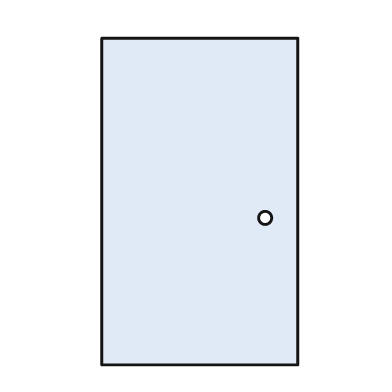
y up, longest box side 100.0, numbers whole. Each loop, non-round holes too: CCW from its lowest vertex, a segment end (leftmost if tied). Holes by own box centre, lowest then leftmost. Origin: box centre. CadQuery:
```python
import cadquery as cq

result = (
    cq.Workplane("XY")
    .moveTo(-30.0, -50.0)
    .lineTo(30.0, -50.0)
    .lineTo(30.0, 50.0)
    .lineTo(-30.0, 50.0)
    .close()
    .moveTo(20.0, -5.0)
    .circle(2.0)
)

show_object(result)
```